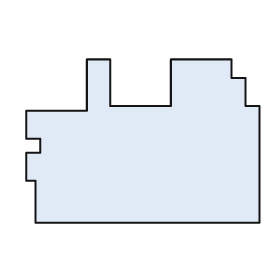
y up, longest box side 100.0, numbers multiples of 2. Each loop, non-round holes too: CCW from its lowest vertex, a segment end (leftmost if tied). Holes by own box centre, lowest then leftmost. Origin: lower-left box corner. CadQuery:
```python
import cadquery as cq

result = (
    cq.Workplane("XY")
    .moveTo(4.0, 0.0)
    .lineTo(100.0, 0.0)
    .lineTo(100.0, 50.0)
    .lineTo(94.0, 50.0)
    .lineTo(94.0, 62.0)
    .lineTo(88.0, 62.0)
    .lineTo(88.0, 70.0)
    .lineTo(62.0, 70.0)
    .lineTo(62.0, 50.0)
    .lineTo(36.0, 50.0)
    .lineTo(36.0, 70.0)
    .lineTo(26.0, 70.0)
    .lineTo(26.0, 48.0)
    .lineTo(0.0, 48.0)
    .lineTo(0.0, 36.0)
    .lineTo(6.0, 36.0)
    .lineTo(6.0, 30.0)
    .lineTo(0.0, 30.0)
    .lineTo(0.0, 18.0)
    .lineTo(4.0, 18.0)
    .close()
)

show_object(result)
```